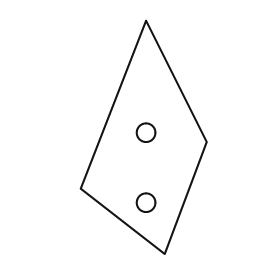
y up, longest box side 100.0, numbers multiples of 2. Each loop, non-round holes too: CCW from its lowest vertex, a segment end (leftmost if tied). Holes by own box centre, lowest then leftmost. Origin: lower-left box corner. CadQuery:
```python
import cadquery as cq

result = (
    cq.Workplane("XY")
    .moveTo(36.0, 0.0)
    .lineTo(54.0, 48.0)
    .lineTo(28.0, 100.0)
    .lineTo(0.0, 28.0)
    .close()
    .moveTo(28.0, 22.0)
    .circle(4.0)
    .moveTo(28.0, 52.0)
    .circle(4.0)
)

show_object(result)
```